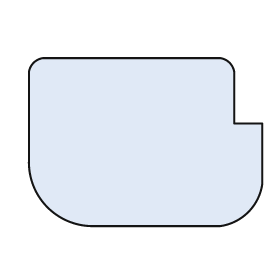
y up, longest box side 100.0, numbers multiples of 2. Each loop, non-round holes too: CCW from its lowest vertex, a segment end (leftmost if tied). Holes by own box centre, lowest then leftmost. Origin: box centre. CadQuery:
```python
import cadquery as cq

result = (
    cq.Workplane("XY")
    .moveTo(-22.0, -36.0)
    .lineTo(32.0, -36.0)
    .threePointArc((44.0, -30.0), (50.0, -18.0))
    .lineTo(50.0, 8.0)
    .lineTo(38.0, 8.0)
    .lineTo(38.0, 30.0)
    .threePointArc((36.0, 34.0), (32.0, 36.0))
    .lineTo(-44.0, 36.0)
    .threePointArc((-48.0, 34.0), (-50.0, 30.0))
    .lineTo(-50.0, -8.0)
    .threePointArc((-42.0, -28.0), (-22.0, -36.0))
    .close()
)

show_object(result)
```